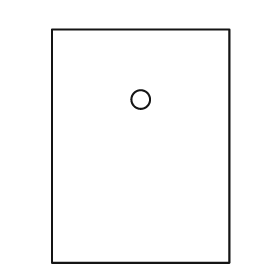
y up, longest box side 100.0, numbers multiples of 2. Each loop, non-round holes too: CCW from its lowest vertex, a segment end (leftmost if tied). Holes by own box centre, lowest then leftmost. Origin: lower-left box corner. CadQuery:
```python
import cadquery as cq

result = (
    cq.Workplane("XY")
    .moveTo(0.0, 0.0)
    .lineTo(76.0, 0.0)
    .lineTo(76.0, 100.0)
    .lineTo(0.0, 100.0)
    .close()
    .moveTo(38.0, 70.0)
    .circle(4.0)
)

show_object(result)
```